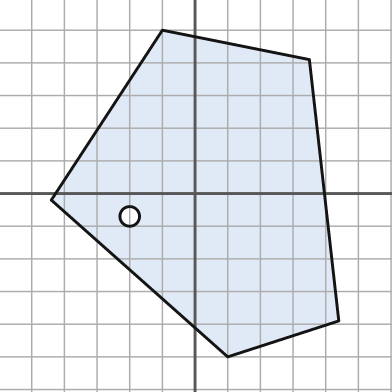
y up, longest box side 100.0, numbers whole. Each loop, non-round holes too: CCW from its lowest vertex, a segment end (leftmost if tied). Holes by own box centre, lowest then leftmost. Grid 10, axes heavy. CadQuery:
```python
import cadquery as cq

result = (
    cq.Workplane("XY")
    .moveTo(10.0, -50.0)
    .lineTo(44.0, -39.0)
    .lineTo(35.0, 41.0)
    .lineTo(-10.0, 50.0)
    .lineTo(-44.0, -2.0)
    .close()
    .moveTo(-20.0, -7.0)
    .circle(3.0)
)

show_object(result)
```